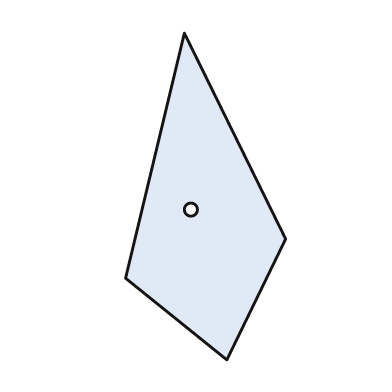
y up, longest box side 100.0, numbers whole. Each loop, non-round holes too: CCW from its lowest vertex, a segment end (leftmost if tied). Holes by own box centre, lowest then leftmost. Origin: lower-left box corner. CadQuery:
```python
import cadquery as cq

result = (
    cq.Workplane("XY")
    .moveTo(31.0, 0.0)
    .lineTo(49.0, 37.0)
    .lineTo(18.0, 100.0)
    .lineTo(0.0, 25.0)
    .close()
    .moveTo(20.0, 46.0)
    .circle(2.0)
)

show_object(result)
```